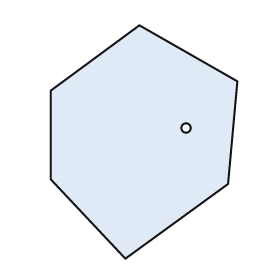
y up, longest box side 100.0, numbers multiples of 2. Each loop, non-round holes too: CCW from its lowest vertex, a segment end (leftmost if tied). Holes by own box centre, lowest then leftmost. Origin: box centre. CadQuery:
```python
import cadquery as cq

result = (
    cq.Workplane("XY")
    .moveTo(-8.0, -50.0)
    .lineTo(36.0, -18.0)
    .lineTo(40.0, 26.0)
    .lineTo(-2.0, 50.0)
    .lineTo(-40.0, 22.0)
    .lineTo(-40.0, -16.0)
    .close()
    .moveTo(18.0, 6.0)
    .circle(2.0)
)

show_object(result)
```